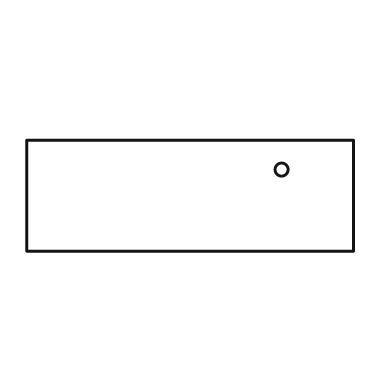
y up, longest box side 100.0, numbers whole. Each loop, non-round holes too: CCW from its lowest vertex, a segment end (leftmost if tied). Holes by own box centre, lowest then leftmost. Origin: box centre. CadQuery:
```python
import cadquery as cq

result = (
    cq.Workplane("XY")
    .moveTo(-50.0, -17.0)
    .lineTo(50.0, -17.0)
    .lineTo(50.0, 17.0)
    .lineTo(-50.0, 17.0)
    .close()
    .moveTo(28.0, 8.0)
    .circle(2.0)
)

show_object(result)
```